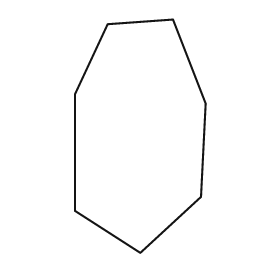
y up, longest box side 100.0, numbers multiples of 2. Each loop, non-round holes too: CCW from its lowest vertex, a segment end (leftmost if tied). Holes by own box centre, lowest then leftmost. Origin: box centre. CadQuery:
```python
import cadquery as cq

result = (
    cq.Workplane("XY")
    .moveTo(0.0, -50.0)
    .lineTo(26.0, -26.0)
    .lineTo(28.0, 14.0)
    .lineTo(14.0, 50.0)
    .lineTo(-14.0, 48.0)
    .lineTo(-28.0, 18.0)
    .lineTo(-28.0, -32.0)
    .close()
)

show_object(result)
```